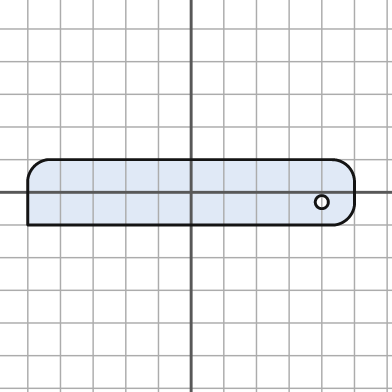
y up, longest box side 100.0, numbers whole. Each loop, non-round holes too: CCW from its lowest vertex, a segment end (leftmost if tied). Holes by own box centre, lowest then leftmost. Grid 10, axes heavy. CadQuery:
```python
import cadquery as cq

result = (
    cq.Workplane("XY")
    .moveTo(-50.0, -10.0)
    .lineTo(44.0, -10.0)
    .threePointArc((48.0, -8.0), (50.0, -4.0))
    .lineTo(50.0, 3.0)
    .threePointArc((48.0, 8.0), (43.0, 10.0))
    .lineTo(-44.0, 10.0)
    .threePointArc((-48.0, 8.0), (-50.0, 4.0))
    .close()
    .moveTo(40.0, -3.0)
    .circle(2.0)
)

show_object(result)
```